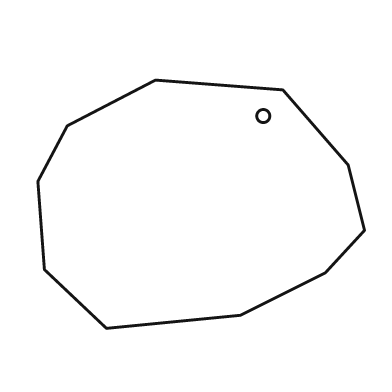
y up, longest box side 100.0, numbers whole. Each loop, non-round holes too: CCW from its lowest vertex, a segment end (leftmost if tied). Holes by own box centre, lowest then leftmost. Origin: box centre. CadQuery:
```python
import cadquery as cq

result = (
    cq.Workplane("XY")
    .moveTo(-29.0, -38.0)
    .lineTo(12.0, -34.0)
    .lineTo(38.0, -21.0)
    .lineTo(50.0, -8.0)
    .lineTo(45.0, 12.0)
    .lineTo(25.0, 35.0)
    .lineTo(-14.0, 38.0)
    .lineTo(-41.0, 24.0)
    .lineTo(-50.0, 7.0)
    .lineTo(-48.0, -20.0)
    .close()
    .moveTo(19.0, 27.0)
    .circle(2.0)
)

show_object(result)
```